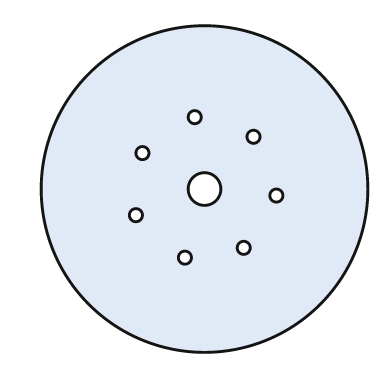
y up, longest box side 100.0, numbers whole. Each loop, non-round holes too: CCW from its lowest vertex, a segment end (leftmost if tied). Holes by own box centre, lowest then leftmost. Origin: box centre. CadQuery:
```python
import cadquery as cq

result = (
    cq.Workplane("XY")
    .moveTo(0.0, 0.0)
    .circle(50.0)
    .moveTo(-6.0, -21.0)
    .circle(2.0)
    .moveTo(12.0, -18.0)
    .circle(2.0)
    .moveTo(-21.0, -8.0)
    .circle(2.0)
    .moveTo(22.0, -2.0)
    .circle(2.0)
    .moveTo(0.0, 0.0)
    .circle(5.0)
    .moveTo(-19.0, 11.0)
    .circle(2.0)
    .moveTo(15.0, 16.0)
    .circle(2.0)
    .moveTo(-3.0, 22.0)
    .circle(2.0)
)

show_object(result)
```